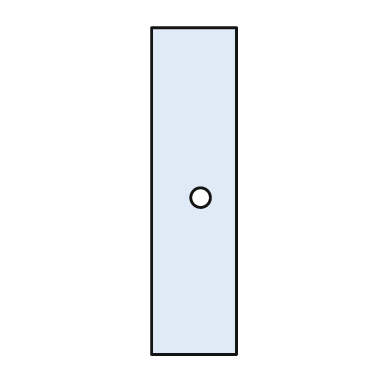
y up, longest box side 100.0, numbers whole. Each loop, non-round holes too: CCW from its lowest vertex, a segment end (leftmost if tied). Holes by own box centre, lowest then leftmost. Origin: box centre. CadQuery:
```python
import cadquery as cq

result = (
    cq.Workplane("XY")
    .moveTo(-13.0, -50.0)
    .lineTo(13.0, -50.0)
    .lineTo(13.0, 50.0)
    .lineTo(-13.0, 50.0)
    .close()
    .moveTo(2.0, -2.0)
    .circle(3.0)
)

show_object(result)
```